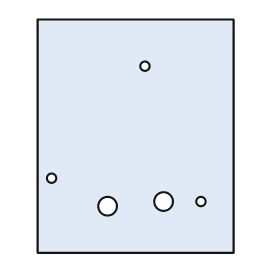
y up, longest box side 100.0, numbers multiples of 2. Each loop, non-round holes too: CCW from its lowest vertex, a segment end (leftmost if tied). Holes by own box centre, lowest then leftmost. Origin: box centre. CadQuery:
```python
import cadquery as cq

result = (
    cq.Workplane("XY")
    .moveTo(-42.0, -50.0)
    .lineTo(42.0, -50.0)
    .lineTo(42.0, 50.0)
    .lineTo(-42.0, 50.0)
    .close()
    .moveTo(-12.0, -30.0)
    .circle(4.0)
    .moveTo(12.0, -28.0)
    .circle(4.0)
    .moveTo(28.0, -28.0)
    .circle(2.0)
    .moveTo(-36.0, -18.0)
    .circle(2.0)
    .moveTo(4.0, 30.0)
    .circle(2.0)
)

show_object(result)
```